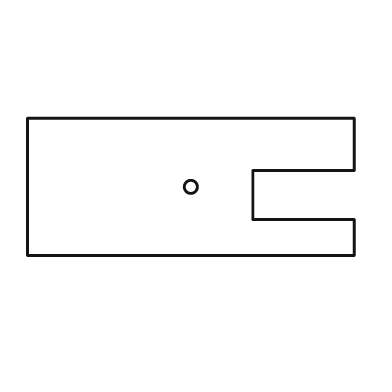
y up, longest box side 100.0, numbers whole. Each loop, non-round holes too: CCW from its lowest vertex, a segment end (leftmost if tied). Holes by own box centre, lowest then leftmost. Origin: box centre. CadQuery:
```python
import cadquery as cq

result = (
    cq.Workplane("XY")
    .moveTo(-50.0, -21.0)
    .lineTo(50.0, -21.0)
    .lineTo(50.0, -10.0)
    .lineTo(19.0, -10.0)
    .lineTo(19.0, 5.0)
    .lineTo(50.0, 5.0)
    .lineTo(50.0, 21.0)
    .lineTo(-50.0, 21.0)
    .close()
    .moveTo(0.0, 0.0)
    .circle(2.0)
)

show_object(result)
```